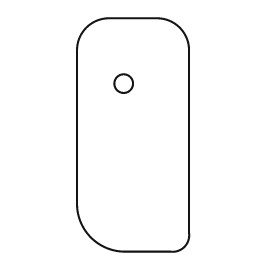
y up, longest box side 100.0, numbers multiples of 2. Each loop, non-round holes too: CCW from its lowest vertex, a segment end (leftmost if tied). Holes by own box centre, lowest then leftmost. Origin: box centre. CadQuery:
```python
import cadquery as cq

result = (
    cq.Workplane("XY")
    .moveTo(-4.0, -50.0)
    .lineTo(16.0, -50.0)
    .threePointArc((22.0, -48.0), (24.0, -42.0))
    .lineTo(24.0, 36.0)
    .threePointArc((20.0, 46.0), (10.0, 50.0))
    .lineTo(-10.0, 50.0)
    .threePointArc((-20.0, 46.0), (-24.0, 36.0))
    .lineTo(-24.0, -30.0)
    .threePointArc((-18.0, -44.0), (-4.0, -50.0))
    .close()
    .moveTo(-4.0, 22.0)
    .circle(4.0)
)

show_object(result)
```